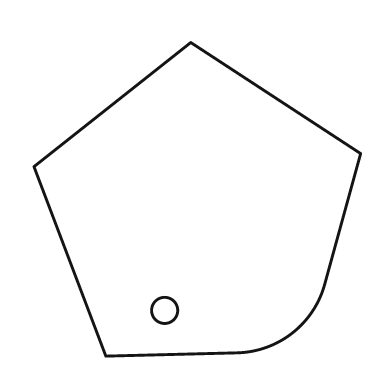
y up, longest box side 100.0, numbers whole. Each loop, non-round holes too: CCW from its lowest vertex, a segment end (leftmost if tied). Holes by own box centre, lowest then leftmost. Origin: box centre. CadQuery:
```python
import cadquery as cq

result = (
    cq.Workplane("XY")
    .moveTo(-28.0, -48.0)
    .lineTo(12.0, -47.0)
    .threePointArc((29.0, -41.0), (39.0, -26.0))
    .lineTo(50.0, 14.0)
    .lineTo(-2.0, 48.0)
    .lineTo(-50.0, 10.0)
    .close()
    .moveTo(-10.0, -34.0)
    .circle(4.0)
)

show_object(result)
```